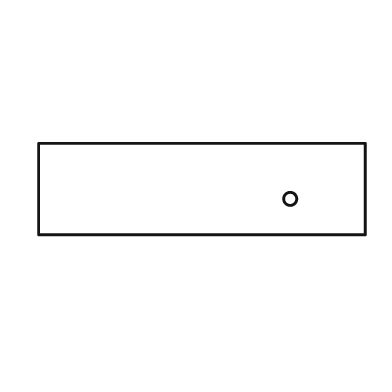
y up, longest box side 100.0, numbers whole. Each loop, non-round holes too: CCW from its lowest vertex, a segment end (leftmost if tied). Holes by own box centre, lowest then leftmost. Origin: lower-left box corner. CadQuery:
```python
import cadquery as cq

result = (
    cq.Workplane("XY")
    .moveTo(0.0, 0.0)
    .lineTo(100.0, 0.0)
    .lineTo(100.0, 28.0)
    .lineTo(0.0, 28.0)
    .close()
    .moveTo(77.0, 11.0)
    .circle(2.0)
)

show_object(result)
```